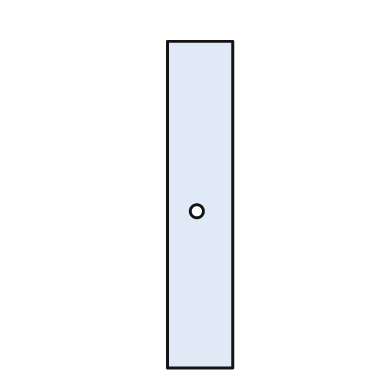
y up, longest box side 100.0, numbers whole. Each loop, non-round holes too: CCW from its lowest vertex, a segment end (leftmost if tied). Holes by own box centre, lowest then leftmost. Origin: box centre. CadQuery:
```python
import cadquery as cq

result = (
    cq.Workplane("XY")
    .moveTo(-10.0, -50.0)
    .lineTo(10.0, -50.0)
    .lineTo(10.0, 50.0)
    .lineTo(-10.0, 50.0)
    .close()
    .moveTo(-1.0, -2.0)
    .circle(2.0)
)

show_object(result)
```